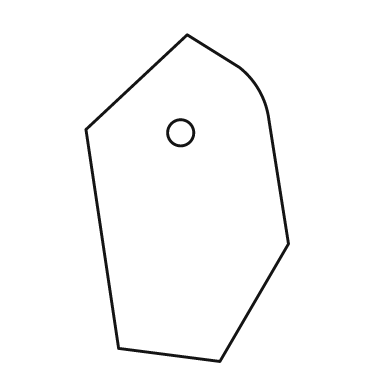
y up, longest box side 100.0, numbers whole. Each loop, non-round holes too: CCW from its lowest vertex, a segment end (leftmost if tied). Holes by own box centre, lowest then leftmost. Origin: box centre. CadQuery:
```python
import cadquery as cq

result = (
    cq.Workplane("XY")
    .moveTo(10.0, -50.0)
    .lineTo(31.0, -14.0)
    .lineTo(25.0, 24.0)
    .threePointArc((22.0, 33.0), (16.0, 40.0))
    .lineTo(0.0, 50.0)
    .lineTo(-31.0, 21.0)
    .lineTo(-21.0, -46.0)
    .close()
    .moveTo(-2.0, 20.0)
    .circle(4.0)
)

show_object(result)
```